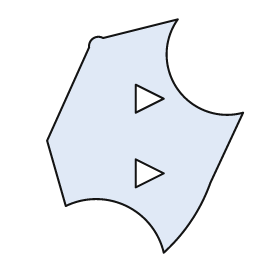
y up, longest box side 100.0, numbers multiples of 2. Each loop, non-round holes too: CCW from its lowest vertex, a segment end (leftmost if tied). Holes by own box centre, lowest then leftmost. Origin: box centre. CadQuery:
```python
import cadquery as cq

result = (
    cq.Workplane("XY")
    .moveTo(8.0, -50.0)
    .threePointArc((20.0, -36.0), (28.0, -20.0))
    .lineTo(42.0, 10.0)
    .threePointArc((14.0, 20.0), (14.0, 50.0))
    .lineTo(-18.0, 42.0)
    .threePointArc((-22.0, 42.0), (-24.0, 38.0))
    .lineTo(-42.0, -2.0)
    .lineTo(-34.0, -30.0)
    .threePointArc((-8.0, -30.0), (8.0, -50.0))
    .close()
    .moveTo(-4.0, -22.0)
    .lineTo(8.0, -16.0)
    .lineTo(-4.0, -10.0)
    .close()
    .moveTo(-4.0, 10.0)
    .lineTo(8.0, 16.0)
    .lineTo(-4.0, 22.0)
    .close()
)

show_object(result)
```